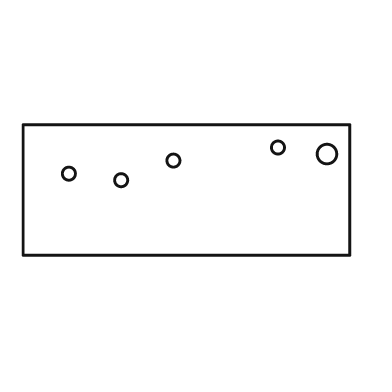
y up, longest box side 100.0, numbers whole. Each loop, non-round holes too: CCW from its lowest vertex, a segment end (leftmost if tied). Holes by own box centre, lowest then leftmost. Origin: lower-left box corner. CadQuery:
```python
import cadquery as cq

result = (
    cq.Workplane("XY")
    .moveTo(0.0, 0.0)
    .lineTo(100.0, 0.0)
    .lineTo(100.0, 40.0)
    .lineTo(0.0, 40.0)
    .close()
    .moveTo(30.0, 23.0)
    .circle(2.0)
    .moveTo(14.0, 25.0)
    .circle(2.0)
    .moveTo(46.0, 29.0)
    .circle(2.0)
    .moveTo(93.0, 31.0)
    .circle(3.0)
    .moveTo(78.0, 33.0)
    .circle(2.0)
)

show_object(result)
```